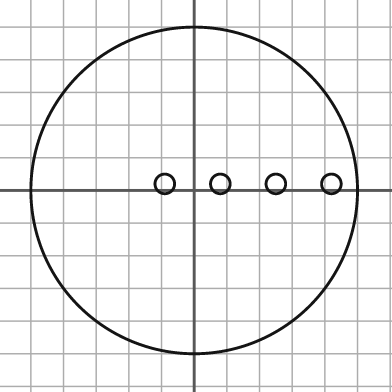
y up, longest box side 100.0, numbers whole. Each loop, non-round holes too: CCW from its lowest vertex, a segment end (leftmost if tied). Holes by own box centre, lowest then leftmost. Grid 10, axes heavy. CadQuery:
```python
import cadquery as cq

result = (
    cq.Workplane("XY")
    .moveTo(0.0, 0.0)
    .circle(50.0)
    .moveTo(-9.0, 2.0)
    .circle(3.0)
    .moveTo(8.0, 2.0)
    .circle(3.0)
    .moveTo(25.0, 2.0)
    .circle(3.0)
    .moveTo(42.0, 2.0)
    .circle(3.0)
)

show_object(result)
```